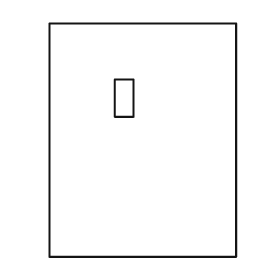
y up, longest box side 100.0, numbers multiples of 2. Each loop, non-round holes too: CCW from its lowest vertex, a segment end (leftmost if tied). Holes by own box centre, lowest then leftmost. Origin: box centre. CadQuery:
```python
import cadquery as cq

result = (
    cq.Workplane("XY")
    .moveTo(-40.0, -50.0)
    .lineTo(40.0, -50.0)
    .lineTo(40.0, 50.0)
    .lineTo(-40.0, 50.0)
    .close()
    .moveTo(-12.0, 10.0)
    .lineTo(-4.0, 10.0)
    .lineTo(-4.0, 26.0)
    .lineTo(-12.0, 26.0)
    .close()
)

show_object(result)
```